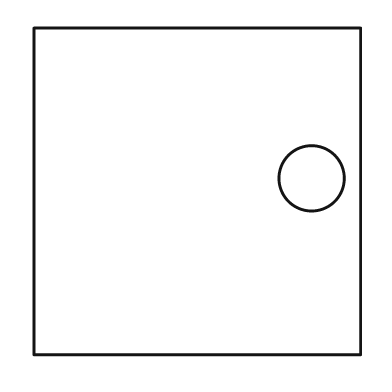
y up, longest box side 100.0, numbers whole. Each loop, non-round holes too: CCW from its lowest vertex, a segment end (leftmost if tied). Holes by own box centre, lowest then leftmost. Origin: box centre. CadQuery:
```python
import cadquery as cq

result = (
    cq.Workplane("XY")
    .moveTo(-50.0, -50.0)
    .lineTo(50.0, -50.0)
    .lineTo(50.0, 50.0)
    .lineTo(-50.0, 50.0)
    .close()
    .moveTo(35.0, 4.0)
    .circle(10.0)
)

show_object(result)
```